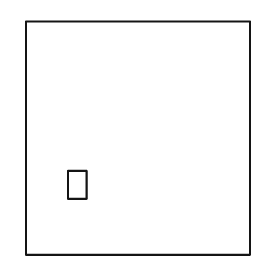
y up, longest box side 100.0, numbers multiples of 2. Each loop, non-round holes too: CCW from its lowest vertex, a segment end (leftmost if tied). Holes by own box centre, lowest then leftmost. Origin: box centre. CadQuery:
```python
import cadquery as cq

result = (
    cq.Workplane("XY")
    .moveTo(-48.0, -50.0)
    .lineTo(48.0, -50.0)
    .lineTo(48.0, 50.0)
    .lineTo(-48.0, 50.0)
    .close()
    .moveTo(-30.0, -26.0)
    .lineTo(-22.0, -26.0)
    .lineTo(-22.0, -14.0)
    .lineTo(-30.0, -14.0)
    .close()
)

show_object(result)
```